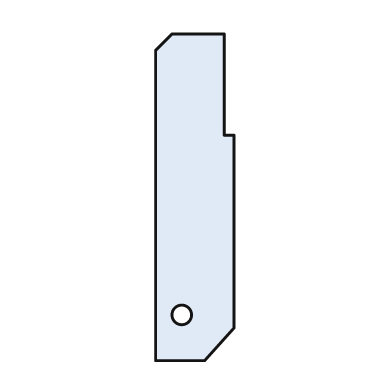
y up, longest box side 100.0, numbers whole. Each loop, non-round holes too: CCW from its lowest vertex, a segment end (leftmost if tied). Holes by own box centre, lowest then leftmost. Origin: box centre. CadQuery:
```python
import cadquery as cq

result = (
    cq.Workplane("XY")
    .moveTo(-12.0, -50.0)
    .lineTo(3.0, -50.0)
    .lineTo(12.0, -40.0)
    .lineTo(12.0, 19.0)
    .lineTo(9.0, 19.0)
    .lineTo(9.0, 50.0)
    .lineTo(-7.0, 50.0)
    .lineTo(-12.0, 45.0)
    .close()
    .moveTo(-4.0, -36.0)
    .circle(3.0)
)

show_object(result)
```